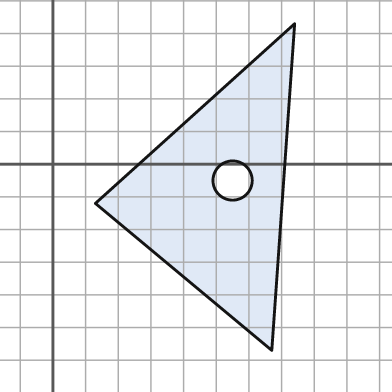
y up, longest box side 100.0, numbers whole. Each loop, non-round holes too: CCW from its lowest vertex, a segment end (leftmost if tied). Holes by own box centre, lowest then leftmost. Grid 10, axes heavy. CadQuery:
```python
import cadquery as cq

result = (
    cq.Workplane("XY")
    .moveTo(67.0, -57.0)
    .lineTo(74.0, 43.0)
    .lineTo(13.0, -12.0)
    .close()
    .moveTo(55.0, -5.0)
    .circle(6.0)
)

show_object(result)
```